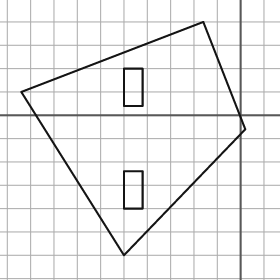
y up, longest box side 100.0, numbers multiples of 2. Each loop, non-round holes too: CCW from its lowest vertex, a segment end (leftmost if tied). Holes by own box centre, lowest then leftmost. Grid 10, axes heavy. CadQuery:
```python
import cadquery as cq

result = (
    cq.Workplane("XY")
    .moveTo(-50.0, -60.0)
    .lineTo(2.0, -6.0)
    .lineTo(-16.0, 40.0)
    .lineTo(-94.0, 10.0)
    .close()
    .moveTo(-50.0, -40.0)
    .lineTo(-42.0, -40.0)
    .lineTo(-42.0, -24.0)
    .lineTo(-50.0, -24.0)
    .close()
    .moveTo(-50.0, 4.0)
    .lineTo(-42.0, 4.0)
    .lineTo(-42.0, 20.0)
    .lineTo(-50.0, 20.0)
    .close()
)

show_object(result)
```